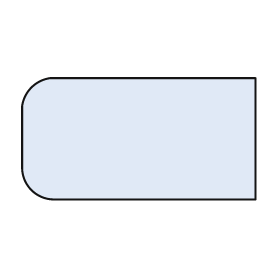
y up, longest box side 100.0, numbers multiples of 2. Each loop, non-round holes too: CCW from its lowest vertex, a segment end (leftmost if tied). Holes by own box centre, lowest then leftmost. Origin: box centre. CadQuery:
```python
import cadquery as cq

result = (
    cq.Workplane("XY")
    .moveTo(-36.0, -26.0)
    .lineTo(50.0, -26.0)
    .lineTo(50.0, 26.0)
    .lineTo(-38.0, 26.0)
    .threePointArc((-46.0, 22.0), (-50.0, 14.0))
    .lineTo(-50.0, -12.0)
    .threePointArc((-46.0, -22.0), (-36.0, -26.0))
    .close()
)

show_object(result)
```